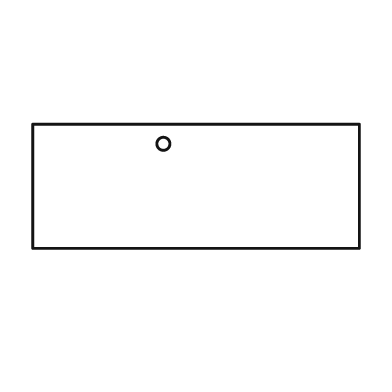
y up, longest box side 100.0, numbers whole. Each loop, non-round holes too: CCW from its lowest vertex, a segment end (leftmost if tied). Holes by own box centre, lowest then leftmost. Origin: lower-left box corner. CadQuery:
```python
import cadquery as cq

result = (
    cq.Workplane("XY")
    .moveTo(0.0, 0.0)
    .lineTo(100.0, 0.0)
    .lineTo(100.0, 38.0)
    .lineTo(0.0, 38.0)
    .close()
    .moveTo(40.0, 32.0)
    .circle(2.0)
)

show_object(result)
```